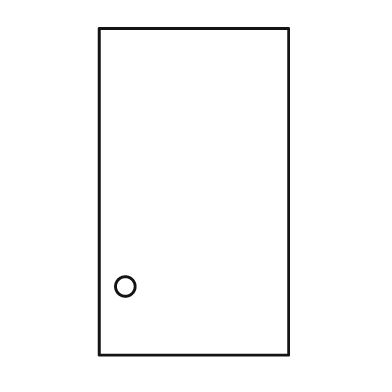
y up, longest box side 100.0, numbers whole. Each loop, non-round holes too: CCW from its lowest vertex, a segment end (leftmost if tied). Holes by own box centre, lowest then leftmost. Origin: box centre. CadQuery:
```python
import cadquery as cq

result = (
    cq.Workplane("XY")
    .moveTo(-29.0, -50.0)
    .lineTo(29.0, -50.0)
    .lineTo(29.0, 50.0)
    .lineTo(-29.0, 50.0)
    .close()
    .moveTo(-21.0, -29.0)
    .circle(3.0)
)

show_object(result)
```